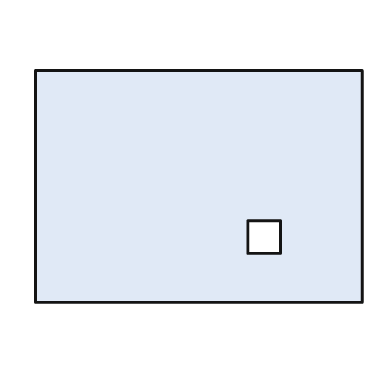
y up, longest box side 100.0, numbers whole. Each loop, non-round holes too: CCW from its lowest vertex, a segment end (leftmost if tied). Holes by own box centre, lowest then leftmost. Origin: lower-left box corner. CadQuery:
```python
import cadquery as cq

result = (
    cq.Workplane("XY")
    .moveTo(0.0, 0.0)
    .lineTo(100.0, 0.0)
    .lineTo(100.0, 71.0)
    .lineTo(0.0, 71.0)
    .close()
    .moveTo(65.0, 15.0)
    .lineTo(75.0, 15.0)
    .lineTo(75.0, 25.0)
    .lineTo(65.0, 25.0)
    .close()
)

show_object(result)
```